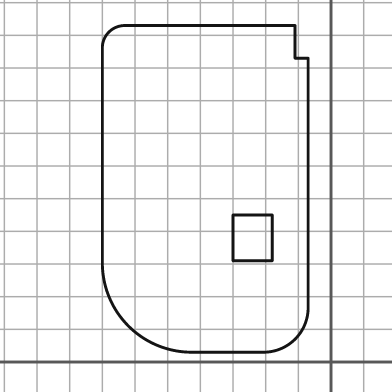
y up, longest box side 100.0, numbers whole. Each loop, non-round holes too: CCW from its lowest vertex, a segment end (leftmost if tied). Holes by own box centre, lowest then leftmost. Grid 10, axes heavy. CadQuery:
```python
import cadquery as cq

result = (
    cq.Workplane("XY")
    .moveTo(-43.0, 3.0)
    .lineTo(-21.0, 3.0)
    .threePointArc((-11.0, 7.0), (-7.0, 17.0))
    .lineTo(-7.0, 93.0)
    .lineTo(-11.0, 93.0)
    .lineTo(-11.0, 103.0)
    .lineTo(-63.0, 103.0)
    .threePointArc((-68.0, 101.0), (-70.0, 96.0))
    .lineTo(-70.0, 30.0)
    .threePointArc((-62.0, 11.0), (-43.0, 3.0))
    .close()
    .moveTo(-30.0, 31.0)
    .lineTo(-18.0, 31.0)
    .lineTo(-18.0, 45.0)
    .lineTo(-30.0, 45.0)
    .close()
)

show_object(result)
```